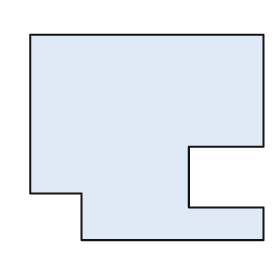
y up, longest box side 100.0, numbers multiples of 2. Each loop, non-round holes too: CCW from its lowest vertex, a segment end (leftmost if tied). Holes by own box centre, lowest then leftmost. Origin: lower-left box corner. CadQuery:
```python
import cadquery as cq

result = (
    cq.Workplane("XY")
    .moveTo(22.0, 0.0)
    .lineTo(100.0, 0.0)
    .lineTo(100.0, 14.0)
    .lineTo(68.0, 14.0)
    .lineTo(68.0, 40.0)
    .lineTo(100.0, 40.0)
    .lineTo(100.0, 88.0)
    .lineTo(0.0, 88.0)
    .lineTo(0.0, 20.0)
    .lineTo(22.0, 20.0)
    .close()
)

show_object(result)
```